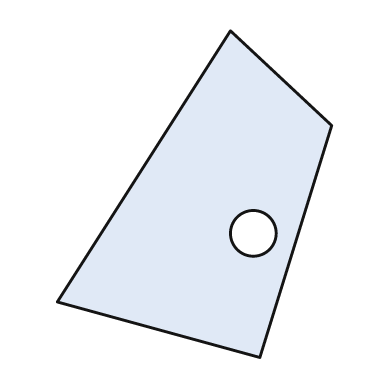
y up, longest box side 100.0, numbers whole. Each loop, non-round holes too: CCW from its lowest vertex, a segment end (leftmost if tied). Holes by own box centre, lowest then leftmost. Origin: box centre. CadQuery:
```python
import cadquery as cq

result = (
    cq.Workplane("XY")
    .moveTo(20.0, -50.0)
    .lineTo(42.0, 21.0)
    .lineTo(11.0, 50.0)
    .lineTo(-42.0, -33.0)
    .close()
    .moveTo(18.0, -12.0)
    .circle(7.0)
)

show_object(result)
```